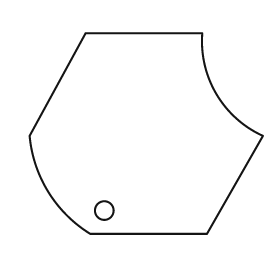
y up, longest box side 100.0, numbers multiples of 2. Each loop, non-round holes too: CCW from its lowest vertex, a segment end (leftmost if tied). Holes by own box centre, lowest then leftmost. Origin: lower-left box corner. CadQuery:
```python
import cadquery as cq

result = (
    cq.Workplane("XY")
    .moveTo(26.0, 0.0)
    .lineTo(76.0, 0.0)
    .lineTo(100.0, 42.0)
    .threePointArc((80.0, 60.0), (74.0, 86.0))
    .lineTo(24.0, 86.0)
    .lineTo(0.0, 42.0)
    .threePointArc((8.0, 18.0), (26.0, 0.0))
    .close()
    .moveTo(32.0, 10.0)
    .circle(4.0)
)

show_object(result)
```